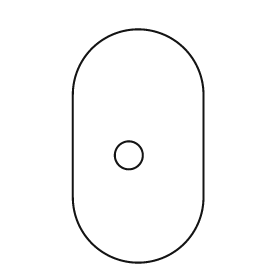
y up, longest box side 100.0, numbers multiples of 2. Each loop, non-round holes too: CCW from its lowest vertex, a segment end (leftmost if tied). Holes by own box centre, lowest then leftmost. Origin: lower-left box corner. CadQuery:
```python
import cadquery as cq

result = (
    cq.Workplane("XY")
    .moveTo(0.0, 28.0)
    .threePointArc((28.0, 0.0), (56.0, 28.0))
    .lineTo(56.0, 72.0)
    .threePointArc((28.0, 100.0), (0.0, 72.0))
    .close()
    .moveTo(24.0, 46.0)
    .circle(6.0)
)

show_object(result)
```